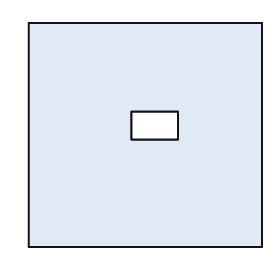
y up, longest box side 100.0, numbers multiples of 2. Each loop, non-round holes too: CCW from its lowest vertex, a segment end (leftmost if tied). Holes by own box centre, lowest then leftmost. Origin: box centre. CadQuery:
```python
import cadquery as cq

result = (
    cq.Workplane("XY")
    .moveTo(-50.0, -48.0)
    .lineTo(50.0, -48.0)
    .lineTo(50.0, 48.0)
    .lineTo(-50.0, 48.0)
    .close()
    .moveTo(-6.0, -2.0)
    .lineTo(14.0, -2.0)
    .lineTo(14.0, 10.0)
    .lineTo(-6.0, 10.0)
    .close()
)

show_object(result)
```